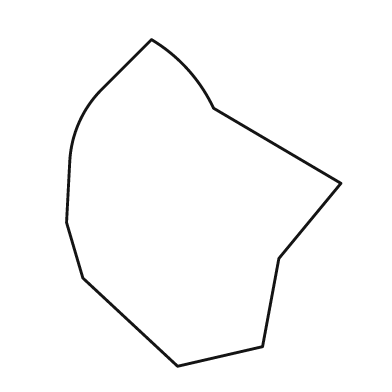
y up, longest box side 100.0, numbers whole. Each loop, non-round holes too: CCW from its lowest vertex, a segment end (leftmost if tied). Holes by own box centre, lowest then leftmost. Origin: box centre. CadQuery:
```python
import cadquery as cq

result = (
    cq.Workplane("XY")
    .moveTo(-8.0, -50.0)
    .lineTo(18.0, -44.0)
    .lineTo(23.0, -17.0)
    .lineTo(42.0, 6.0)
    .lineTo(3.0, 29.0)
    .threePointArc((-5.0, 41.0), (-16.0, 50.0))
    .lineTo(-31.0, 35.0)
    .threePointArc((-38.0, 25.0), (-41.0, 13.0))
    .lineTo(-42.0, -6.0)
    .lineTo(-37.0, -23.0)
    .close()
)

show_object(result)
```